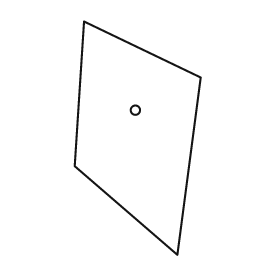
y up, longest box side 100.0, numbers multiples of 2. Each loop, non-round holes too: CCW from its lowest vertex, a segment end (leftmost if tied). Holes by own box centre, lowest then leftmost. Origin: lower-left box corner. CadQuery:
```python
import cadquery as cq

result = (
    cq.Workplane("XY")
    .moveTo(44.0, 0.0)
    .lineTo(54.0, 76.0)
    .lineTo(4.0, 100.0)
    .lineTo(0.0, 38.0)
    .close()
    .moveTo(26.0, 62.0)
    .circle(2.0)
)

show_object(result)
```